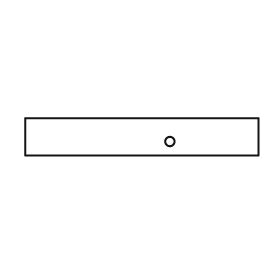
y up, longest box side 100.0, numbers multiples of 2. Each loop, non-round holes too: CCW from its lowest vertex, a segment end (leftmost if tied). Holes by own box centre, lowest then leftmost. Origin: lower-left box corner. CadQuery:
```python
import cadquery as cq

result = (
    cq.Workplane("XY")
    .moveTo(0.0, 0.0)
    .lineTo(100.0, 0.0)
    .lineTo(100.0, 16.0)
    .lineTo(0.0, 16.0)
    .close()
    .moveTo(62.0, 6.0)
    .circle(2.0)
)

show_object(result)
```